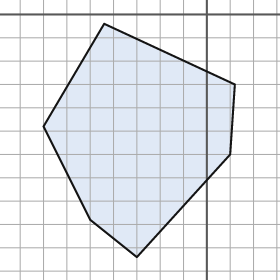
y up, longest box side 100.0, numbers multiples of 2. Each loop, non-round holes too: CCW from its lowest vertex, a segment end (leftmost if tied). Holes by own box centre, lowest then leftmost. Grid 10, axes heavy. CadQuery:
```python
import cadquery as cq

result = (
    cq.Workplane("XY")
    .moveTo(-30.0, -104.0)
    .lineTo(10.0, -60.0)
    .lineTo(12.0, -30.0)
    .lineTo(-44.0, -4.0)
    .lineTo(-70.0, -48.0)
    .lineTo(-50.0, -88.0)
    .close()
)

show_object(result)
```